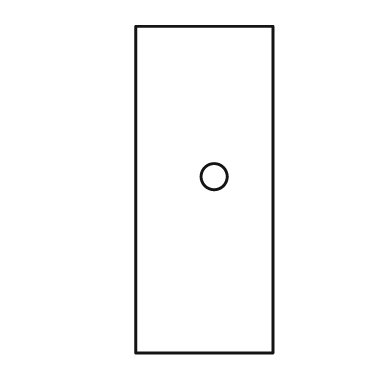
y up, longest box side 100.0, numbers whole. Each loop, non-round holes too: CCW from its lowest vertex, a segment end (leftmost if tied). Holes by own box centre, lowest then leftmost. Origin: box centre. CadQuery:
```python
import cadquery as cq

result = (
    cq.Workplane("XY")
    .moveTo(-21.0, -50.0)
    .lineTo(21.0, -50.0)
    .lineTo(21.0, 50.0)
    .lineTo(-21.0, 50.0)
    .close()
    .moveTo(3.0, 4.0)
    .circle(4.0)
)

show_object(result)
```